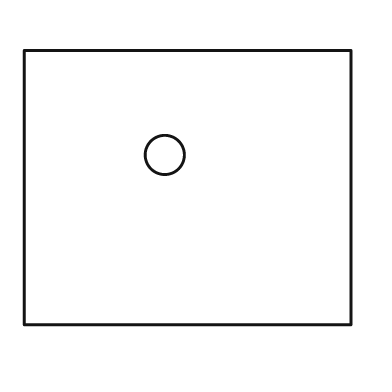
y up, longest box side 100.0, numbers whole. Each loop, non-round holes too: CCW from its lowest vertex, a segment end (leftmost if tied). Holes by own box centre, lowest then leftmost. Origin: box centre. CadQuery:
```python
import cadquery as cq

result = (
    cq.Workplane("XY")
    .moveTo(-50.0, -42.0)
    .lineTo(50.0, -42.0)
    .lineTo(50.0, 42.0)
    .lineTo(-50.0, 42.0)
    .close()
    .moveTo(-7.0, 10.0)
    .circle(6.0)
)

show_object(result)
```